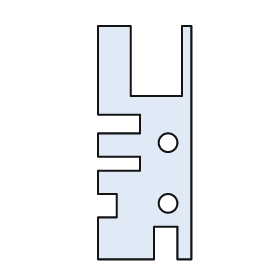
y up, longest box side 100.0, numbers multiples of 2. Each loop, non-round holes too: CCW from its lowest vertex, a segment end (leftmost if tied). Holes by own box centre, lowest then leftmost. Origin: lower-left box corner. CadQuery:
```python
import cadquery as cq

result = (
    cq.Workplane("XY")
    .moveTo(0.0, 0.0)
    .lineTo(24.0, 0.0)
    .lineTo(24.0, 14.0)
    .lineTo(34.0, 14.0)
    .lineTo(34.0, 0.0)
    .lineTo(40.0, 0.0)
    .lineTo(40.0, 100.0)
    .lineTo(36.0, 100.0)
    .lineTo(36.0, 70.0)
    .lineTo(14.0, 70.0)
    .lineTo(14.0, 100.0)
    .lineTo(0.0, 100.0)
    .lineTo(0.0, 62.0)
    .lineTo(18.0, 62.0)
    .lineTo(18.0, 54.0)
    .lineTo(0.0, 54.0)
    .lineTo(0.0, 44.0)
    .lineTo(18.0, 44.0)
    .lineTo(18.0, 38.0)
    .lineTo(0.0, 38.0)
    .lineTo(0.0, 28.0)
    .lineTo(8.0, 28.0)
    .lineTo(8.0, 18.0)
    .lineTo(0.0, 18.0)
    .close()
    .moveTo(30.0, 24.0)
    .circle(4.0)
    .moveTo(30.0, 50.0)
    .circle(4.0)
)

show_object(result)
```